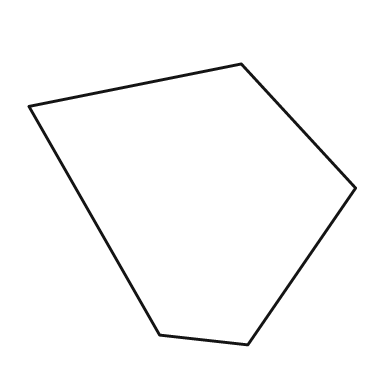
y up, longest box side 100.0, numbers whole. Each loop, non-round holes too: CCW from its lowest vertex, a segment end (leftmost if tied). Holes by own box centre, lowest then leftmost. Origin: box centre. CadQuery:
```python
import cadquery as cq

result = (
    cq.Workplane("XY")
    .moveTo(17.0, -43.0)
    .lineTo(50.0, 5.0)
    .lineTo(15.0, 43.0)
    .lineTo(-50.0, 30.0)
    .lineTo(-10.0, -40.0)
    .close()
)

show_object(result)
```